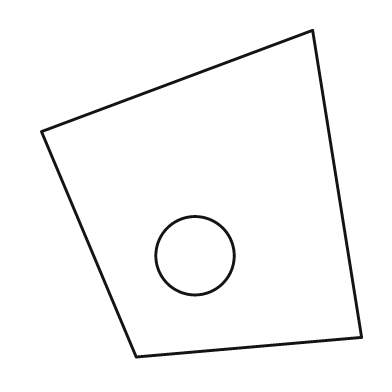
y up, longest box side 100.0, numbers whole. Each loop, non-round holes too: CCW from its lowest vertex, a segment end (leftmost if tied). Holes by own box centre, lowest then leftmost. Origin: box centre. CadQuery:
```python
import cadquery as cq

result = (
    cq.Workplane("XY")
    .moveTo(-20.0, -50.0)
    .lineTo(49.0, -44.0)
    .lineTo(34.0, 50.0)
    .lineTo(-49.0, 19.0)
    .close()
    .moveTo(-2.0, -19.0)
    .circle(12.0)
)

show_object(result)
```